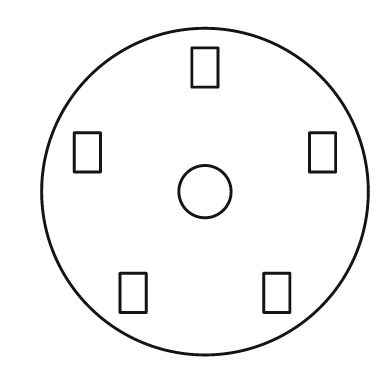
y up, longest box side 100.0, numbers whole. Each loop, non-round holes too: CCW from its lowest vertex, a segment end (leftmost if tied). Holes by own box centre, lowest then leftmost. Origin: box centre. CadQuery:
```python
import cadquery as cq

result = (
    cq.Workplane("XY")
    .moveTo(0.0, 0.0)
    .circle(50.0)
    .moveTo(-26.0, -37.0)
    .lineTo(-18.0, -37.0)
    .lineTo(-18.0, -25.0)
    .lineTo(-26.0, -25.0)
    .close()
    .moveTo(18.0, -37.0)
    .lineTo(26.0, -37.0)
    .lineTo(26.0, -25.0)
    .lineTo(18.0, -25.0)
    .close()
    .moveTo(0.0, 0.0)
    .circle(8.0)
    .moveTo(-40.0, 6.0)
    .lineTo(-32.0, 6.0)
    .lineTo(-32.0, 18.0)
    .lineTo(-40.0, 18.0)
    .close()
    .moveTo(32.0, 6.0)
    .lineTo(40.0, 6.0)
    .lineTo(40.0, 18.0)
    .lineTo(32.0, 18.0)
    .close()
    .moveTo(-4.0, 32.0)
    .lineTo(4.0, 32.0)
    .lineTo(4.0, 44.0)
    .lineTo(-4.0, 44.0)
    .close()
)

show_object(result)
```